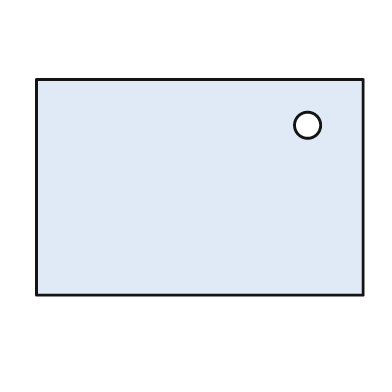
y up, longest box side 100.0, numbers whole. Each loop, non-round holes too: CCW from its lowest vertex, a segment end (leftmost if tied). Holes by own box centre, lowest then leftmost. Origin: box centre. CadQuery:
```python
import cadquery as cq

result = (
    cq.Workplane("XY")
    .moveTo(-50.0, -33.0)
    .lineTo(50.0, -33.0)
    .lineTo(50.0, 33.0)
    .lineTo(-50.0, 33.0)
    .close()
    .moveTo(33.0, 19.0)
    .circle(4.0)
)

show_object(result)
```